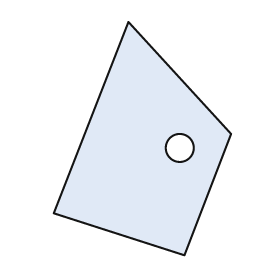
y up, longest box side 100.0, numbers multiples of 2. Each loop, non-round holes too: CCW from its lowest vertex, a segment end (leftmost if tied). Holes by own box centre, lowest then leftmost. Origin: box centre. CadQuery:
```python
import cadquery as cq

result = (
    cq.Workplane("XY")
    .moveTo(18.0, -50.0)
    .lineTo(38.0, 2.0)
    .lineTo(-6.0, 50.0)
    .lineTo(-38.0, -32.0)
    .close()
    .moveTo(16.0, -4.0)
    .circle(6.0)
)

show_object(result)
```